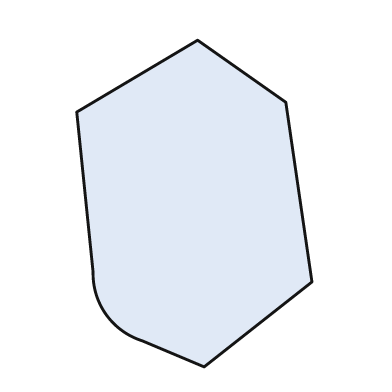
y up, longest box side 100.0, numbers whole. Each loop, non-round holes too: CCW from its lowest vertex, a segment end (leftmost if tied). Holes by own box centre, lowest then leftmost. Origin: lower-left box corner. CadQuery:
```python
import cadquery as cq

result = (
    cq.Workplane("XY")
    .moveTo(39.0, 0.0)
    .lineTo(72.0, 26.0)
    .lineTo(64.0, 81.0)
    .lineTo(37.0, 100.0)
    .lineTo(0.0, 78.0)
    .lineTo(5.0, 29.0)
    .threePointArc((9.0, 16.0), (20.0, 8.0))
    .close()
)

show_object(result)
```